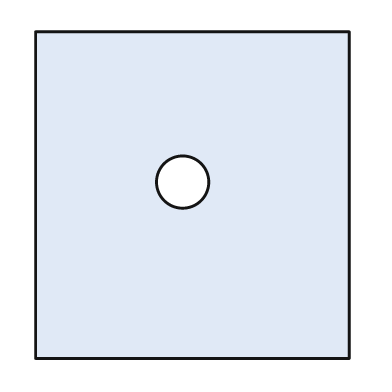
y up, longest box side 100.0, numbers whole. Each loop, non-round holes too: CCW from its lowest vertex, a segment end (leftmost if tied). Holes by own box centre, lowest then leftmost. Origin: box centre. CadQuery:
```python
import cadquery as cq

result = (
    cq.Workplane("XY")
    .moveTo(-48.0, -50.0)
    .lineTo(48.0, -50.0)
    .lineTo(48.0, 50.0)
    .lineTo(-48.0, 50.0)
    .close()
    .moveTo(-3.0, 4.0)
    .circle(8.0)
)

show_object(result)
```